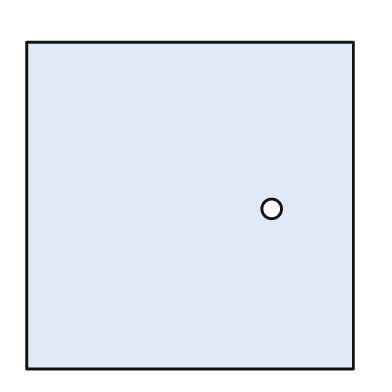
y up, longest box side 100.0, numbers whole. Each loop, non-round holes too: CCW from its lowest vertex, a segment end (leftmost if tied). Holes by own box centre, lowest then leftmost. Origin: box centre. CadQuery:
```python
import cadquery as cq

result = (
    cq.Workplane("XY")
    .moveTo(-50.0, -50.0)
    .lineTo(50.0, -50.0)
    .lineTo(50.0, 50.0)
    .lineTo(-50.0, 50.0)
    .close()
    .moveTo(25.0, -1.0)
    .circle(3.0)
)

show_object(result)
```